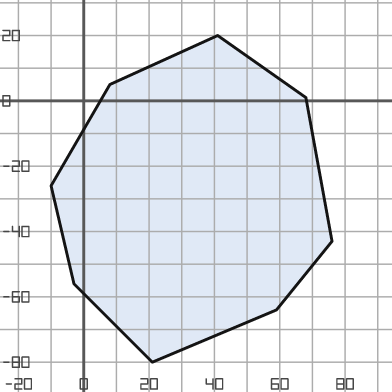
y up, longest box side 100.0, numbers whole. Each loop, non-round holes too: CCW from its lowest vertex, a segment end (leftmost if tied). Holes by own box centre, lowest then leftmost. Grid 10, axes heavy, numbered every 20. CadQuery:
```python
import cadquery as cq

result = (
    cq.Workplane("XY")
    .moveTo(21.0, -80.0)
    .lineTo(59.0, -64.0)
    .lineTo(76.0, -43.0)
    .lineTo(68.0, 1.0)
    .lineTo(41.0, 20.0)
    .lineTo(8.0, 5.0)
    .lineTo(-10.0, -26.0)
    .lineTo(-3.0, -56.0)
    .close()
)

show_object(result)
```